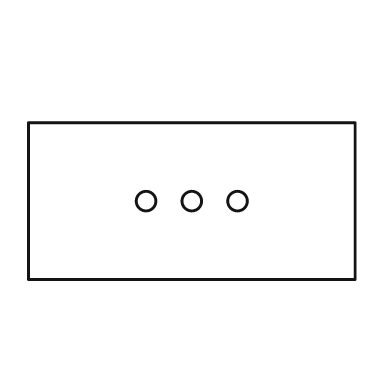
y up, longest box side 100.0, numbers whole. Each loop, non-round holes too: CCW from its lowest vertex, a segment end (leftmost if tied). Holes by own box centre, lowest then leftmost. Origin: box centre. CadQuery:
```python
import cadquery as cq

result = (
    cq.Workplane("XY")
    .moveTo(-50.0, -24.0)
    .lineTo(50.0, -24.0)
    .lineTo(50.0, 24.0)
    .lineTo(-50.0, 24.0)
    .close()
    .moveTo(-14.0, 0.0)
    .circle(3.0)
    .moveTo(0.0, 0.0)
    .circle(3.0)
    .moveTo(14.0, 0.0)
    .circle(3.0)
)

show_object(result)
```